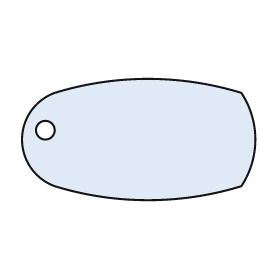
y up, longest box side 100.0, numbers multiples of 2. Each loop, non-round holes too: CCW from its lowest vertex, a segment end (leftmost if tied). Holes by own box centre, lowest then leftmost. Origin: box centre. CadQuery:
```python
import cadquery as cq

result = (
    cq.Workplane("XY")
    .moveTo(-36.0, -20.0)
    .threePointArc((4.0, -26.0), (44.0, -20.0))
    .threePointArc((50.0, 0.0), (44.0, 20.0))
    .threePointArc((4.0, 26.0), (-36.0, 20.0))
    .threePointArc((-50.0, 0.0), (-36.0, -20.0))
    .close()
    .moveTo(-40.0, 4.0)
    .circle(4.0)
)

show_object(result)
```